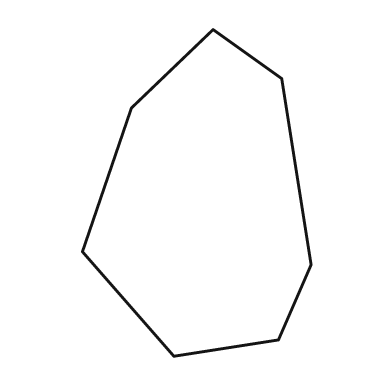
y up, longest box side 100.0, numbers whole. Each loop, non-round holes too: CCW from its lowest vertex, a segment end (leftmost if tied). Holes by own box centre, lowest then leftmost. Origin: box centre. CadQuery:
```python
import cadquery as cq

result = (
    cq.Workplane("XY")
    .moveTo(-7.0, -50.0)
    .lineTo(25.0, -45.0)
    .lineTo(35.0, -22.0)
    .lineTo(26.0, 35.0)
    .lineTo(5.0, 50.0)
    .lineTo(-20.0, 26.0)
    .lineTo(-35.0, -18.0)
    .close()
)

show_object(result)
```